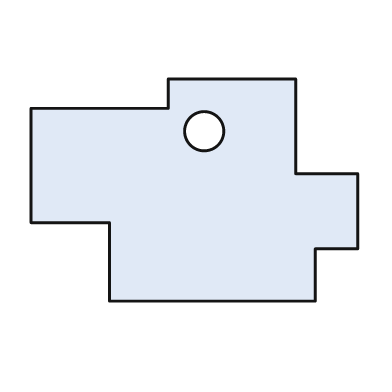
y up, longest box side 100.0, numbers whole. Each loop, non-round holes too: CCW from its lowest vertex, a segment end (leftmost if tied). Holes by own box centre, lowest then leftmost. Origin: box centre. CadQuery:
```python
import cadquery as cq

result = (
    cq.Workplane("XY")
    .moveTo(-26.0, -34.0)
    .lineTo(37.0, -34.0)
    .lineTo(37.0, -18.0)
    .lineTo(50.0, -18.0)
    .lineTo(50.0, 5.0)
    .lineTo(31.0, 5.0)
    .lineTo(31.0, 34.0)
    .lineTo(-8.0, 34.0)
    .lineTo(-8.0, 25.0)
    .lineTo(-50.0, 25.0)
    .lineTo(-50.0, -10.0)
    .lineTo(-26.0, -10.0)
    .close()
    .moveTo(3.0, 18.0)
    .circle(6.0)
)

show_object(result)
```